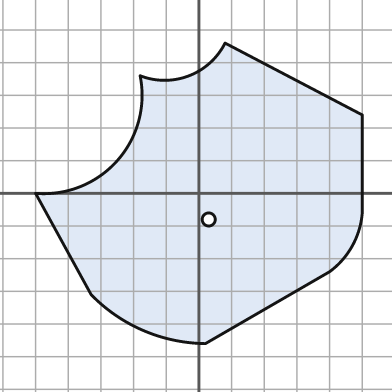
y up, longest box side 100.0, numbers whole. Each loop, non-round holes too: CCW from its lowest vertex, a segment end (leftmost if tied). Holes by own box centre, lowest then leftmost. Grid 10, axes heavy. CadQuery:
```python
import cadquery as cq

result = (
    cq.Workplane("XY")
    .moveTo(2.0, -46.0)
    .lineTo(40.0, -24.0)
    .threePointArc((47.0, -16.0), (50.0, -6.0))
    .lineTo(50.0, 24.0)
    .lineTo(8.0, 46.0)
    .threePointArc((-3.0, 36.0), (-18.0, 36.0))
    .threePointArc((-25.0, 10.0), (-50.0, 0.0))
    .lineTo(-33.0, -31.0)
    .threePointArc((-17.0, -42.0), (2.0, -46.0))
    .close()
    .moveTo(3.0, -8.0)
    .circle(2.0)
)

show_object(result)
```